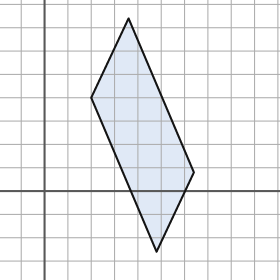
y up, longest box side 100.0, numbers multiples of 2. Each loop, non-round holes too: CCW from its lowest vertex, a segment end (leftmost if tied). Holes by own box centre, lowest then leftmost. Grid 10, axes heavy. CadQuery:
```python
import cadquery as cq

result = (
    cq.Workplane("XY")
    .moveTo(48.0, -26.0)
    .lineTo(64.0, 8.0)
    .lineTo(36.0, 74.0)
    .lineTo(20.0, 40.0)
    .close()
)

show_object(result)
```